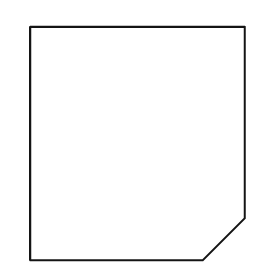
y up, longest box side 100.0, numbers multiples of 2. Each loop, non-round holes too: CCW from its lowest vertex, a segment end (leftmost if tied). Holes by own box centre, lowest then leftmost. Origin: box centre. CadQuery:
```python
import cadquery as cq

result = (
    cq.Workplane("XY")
    .moveTo(-46.0, -50.0)
    .lineTo(28.0, -50.0)
    .lineTo(46.0, -32.0)
    .lineTo(46.0, 50.0)
    .lineTo(-46.0, 50.0)
    .close()
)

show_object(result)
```